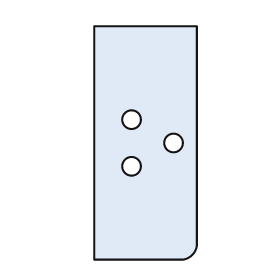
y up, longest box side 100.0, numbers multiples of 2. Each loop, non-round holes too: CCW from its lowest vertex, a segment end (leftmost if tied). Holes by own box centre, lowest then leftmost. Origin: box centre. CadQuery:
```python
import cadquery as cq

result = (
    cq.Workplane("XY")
    .moveTo(-22.0, -50.0)
    .lineTo(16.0, -50.0)
    .threePointArc((20.0, -48.0), (22.0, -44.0))
    .lineTo(22.0, 50.0)
    .lineTo(-22.0, 50.0)
    .close()
    .moveTo(-6.0, -10.0)
    .circle(4.0)
    .moveTo(12.0, 0.0)
    .circle(4.0)
    .moveTo(-6.0, 10.0)
    .circle(4.0)
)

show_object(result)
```